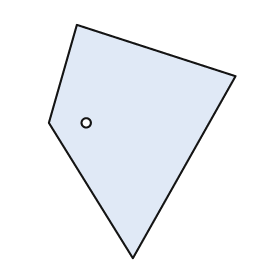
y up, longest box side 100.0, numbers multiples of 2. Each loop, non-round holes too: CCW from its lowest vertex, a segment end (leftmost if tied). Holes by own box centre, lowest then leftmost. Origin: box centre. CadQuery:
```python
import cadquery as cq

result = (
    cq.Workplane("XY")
    .moveTo(-4.0, -50.0)
    .lineTo(40.0, 28.0)
    .lineTo(-28.0, 50.0)
    .lineTo(-40.0, 8.0)
    .close()
    .moveTo(-24.0, 8.0)
    .circle(2.0)
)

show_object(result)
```